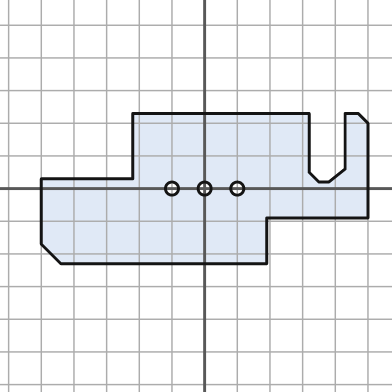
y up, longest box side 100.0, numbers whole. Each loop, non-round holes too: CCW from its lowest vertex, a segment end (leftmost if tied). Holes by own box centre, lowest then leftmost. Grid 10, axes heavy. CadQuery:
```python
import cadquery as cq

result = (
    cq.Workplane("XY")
    .moveTo(-44.0, -23.0)
    .lineTo(19.0, -23.0)
    .lineTo(19.0, -9.0)
    .lineTo(50.0, -9.0)
    .lineTo(50.0, 20.0)
    .lineTo(47.0, 23.0)
    .lineTo(43.0, 23.0)
    .lineTo(43.0, 6.0)
    .lineTo(38.0, 2.0)
    .lineTo(35.0, 2.0)
    .lineTo(32.0, 5.0)
    .lineTo(32.0, 23.0)
    .lineTo(-22.0, 23.0)
    .lineTo(-22.0, 3.0)
    .lineTo(-50.0, 3.0)
    .lineTo(-50.0, -17.0)
    .close()
    .moveTo(-10.0, 0.0)
    .circle(2.0)
    .moveTo(0.0, 0.0)
    .circle(2.0)
    .moveTo(10.0, 0.0)
    .circle(2.0)
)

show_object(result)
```